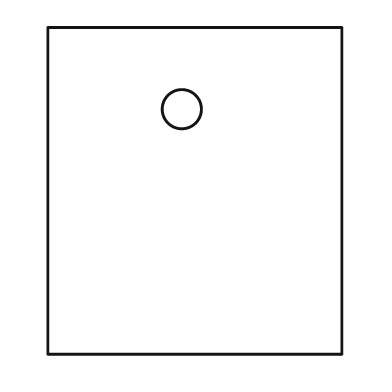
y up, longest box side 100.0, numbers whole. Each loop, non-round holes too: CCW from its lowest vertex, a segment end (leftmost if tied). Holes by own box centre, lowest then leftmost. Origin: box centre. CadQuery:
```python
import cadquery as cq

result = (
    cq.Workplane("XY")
    .moveTo(-45.0, -50.0)
    .lineTo(45.0, -50.0)
    .lineTo(45.0, 50.0)
    .lineTo(-45.0, 50.0)
    .close()
    .moveTo(-4.0, 25.0)
    .circle(6.0)
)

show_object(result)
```